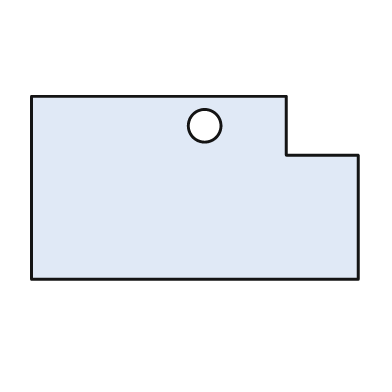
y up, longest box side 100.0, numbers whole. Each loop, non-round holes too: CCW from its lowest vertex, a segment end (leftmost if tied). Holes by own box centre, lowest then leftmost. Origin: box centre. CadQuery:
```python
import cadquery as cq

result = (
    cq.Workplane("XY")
    .moveTo(-50.0, -28.0)
    .lineTo(50.0, -28.0)
    .lineTo(50.0, 10.0)
    .lineTo(28.0, 10.0)
    .lineTo(28.0, 28.0)
    .lineTo(-50.0, 28.0)
    .close()
    .moveTo(3.0, 19.0)
    .circle(5.0)
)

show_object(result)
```